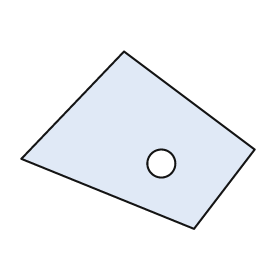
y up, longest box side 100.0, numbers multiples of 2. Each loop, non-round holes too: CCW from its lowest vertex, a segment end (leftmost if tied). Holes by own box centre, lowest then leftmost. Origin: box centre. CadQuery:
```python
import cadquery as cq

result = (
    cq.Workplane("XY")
    .moveTo(24.0, -38.0)
    .lineTo(50.0, -4.0)
    .lineTo(-6.0, 38.0)
    .lineTo(-50.0, -8.0)
    .close()
    .moveTo(10.0, -10.0)
    .circle(6.0)
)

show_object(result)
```